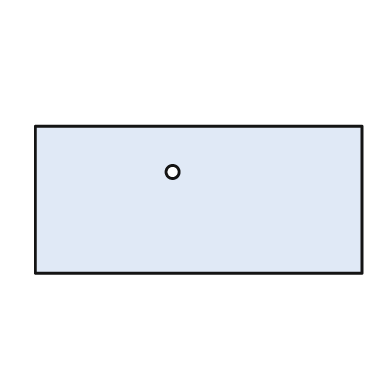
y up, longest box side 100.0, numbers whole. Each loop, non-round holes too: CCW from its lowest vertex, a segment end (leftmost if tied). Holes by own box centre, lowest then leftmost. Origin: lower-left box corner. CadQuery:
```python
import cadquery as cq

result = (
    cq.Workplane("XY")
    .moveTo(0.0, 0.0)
    .lineTo(100.0, 0.0)
    .lineTo(100.0, 45.0)
    .lineTo(0.0, 45.0)
    .close()
    .moveTo(42.0, 31.0)
    .circle(2.0)
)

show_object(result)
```